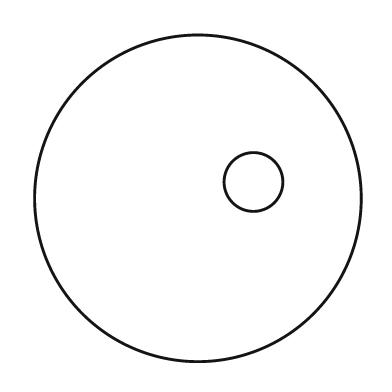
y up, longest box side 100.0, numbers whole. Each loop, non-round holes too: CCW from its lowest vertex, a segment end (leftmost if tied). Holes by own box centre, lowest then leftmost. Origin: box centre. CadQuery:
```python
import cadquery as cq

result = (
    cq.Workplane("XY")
    .moveTo(0.0, 0.0)
    .circle(50.0)
    .moveTo(17.0, 5.0)
    .circle(9.0)
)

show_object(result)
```